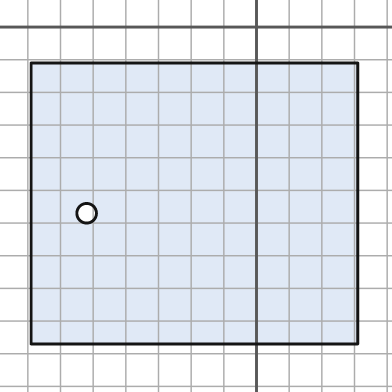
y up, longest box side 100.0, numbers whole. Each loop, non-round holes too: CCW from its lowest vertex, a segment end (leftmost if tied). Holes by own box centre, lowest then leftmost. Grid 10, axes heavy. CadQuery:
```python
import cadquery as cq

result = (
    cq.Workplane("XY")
    .moveTo(-69.0, -97.0)
    .lineTo(31.0, -97.0)
    .lineTo(31.0, -11.0)
    .lineTo(-69.0, -11.0)
    .close()
    .moveTo(-52.0, -57.0)
    .circle(3.0)
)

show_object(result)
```